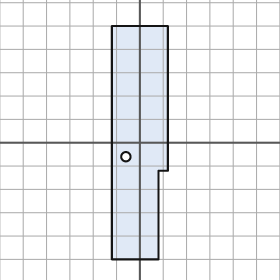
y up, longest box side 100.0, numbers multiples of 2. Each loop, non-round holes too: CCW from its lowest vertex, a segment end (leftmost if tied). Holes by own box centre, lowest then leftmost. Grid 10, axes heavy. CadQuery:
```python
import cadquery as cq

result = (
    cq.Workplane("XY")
    .moveTo(-12.0, -50.0)
    .lineTo(8.0, -50.0)
    .lineTo(8.0, -12.0)
    .lineTo(12.0, -12.0)
    .lineTo(12.0, 50.0)
    .lineTo(-12.0, 50.0)
    .close()
    .moveTo(-6.0, -6.0)
    .circle(2.0)
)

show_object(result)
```